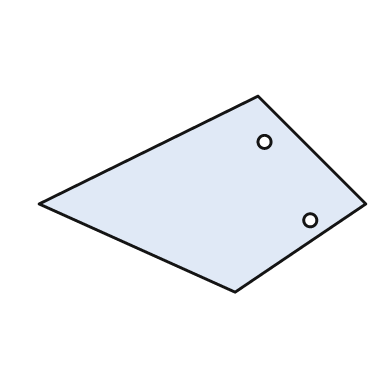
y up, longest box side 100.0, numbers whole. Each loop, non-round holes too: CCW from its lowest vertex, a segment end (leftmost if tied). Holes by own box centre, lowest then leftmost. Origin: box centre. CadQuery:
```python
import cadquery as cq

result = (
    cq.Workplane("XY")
    .moveTo(10.0, -30.0)
    .lineTo(50.0, -3.0)
    .lineTo(17.0, 30.0)
    .lineTo(-50.0, -3.0)
    .close()
    .moveTo(33.0, -8.0)
    .circle(2.0)
    .moveTo(19.0, 16.0)
    .circle(2.0)
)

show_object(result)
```